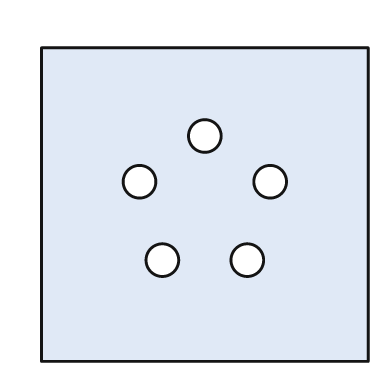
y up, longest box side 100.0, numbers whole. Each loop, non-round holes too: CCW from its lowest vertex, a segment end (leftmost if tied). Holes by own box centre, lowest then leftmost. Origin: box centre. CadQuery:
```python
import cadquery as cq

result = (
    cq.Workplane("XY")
    .moveTo(-50.0, -48.0)
    .lineTo(50.0, -48.0)
    .lineTo(50.0, 48.0)
    .lineTo(-50.0, 48.0)
    .close()
    .moveTo(-13.0, -17.0)
    .circle(5.0)
    .moveTo(13.0, -17.0)
    .circle(5.0)
    .moveTo(-20.0, 7.0)
    .circle(5.0)
    .moveTo(20.0, 7.0)
    .circle(5.0)
    .moveTo(0.0, 21.0)
    .circle(5.0)
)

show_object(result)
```